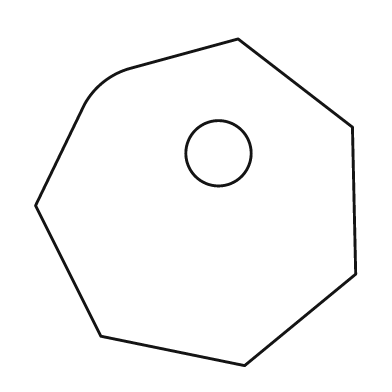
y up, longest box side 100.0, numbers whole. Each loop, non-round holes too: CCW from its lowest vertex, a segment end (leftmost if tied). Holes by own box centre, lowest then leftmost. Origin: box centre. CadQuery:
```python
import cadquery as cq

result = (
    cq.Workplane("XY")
    .moveTo(15.0, -50.0)
    .lineTo(49.0, -22.0)
    .lineTo(48.0, 23.0)
    .lineTo(13.0, 50.0)
    .lineTo(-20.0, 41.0)
    .threePointArc((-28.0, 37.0), (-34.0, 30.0))
    .lineTo(-49.0, -1.0)
    .lineTo(-29.0, -41.0)
    .close()
    .moveTo(7.0, 15.0)
    .circle(10.0)
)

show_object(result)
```